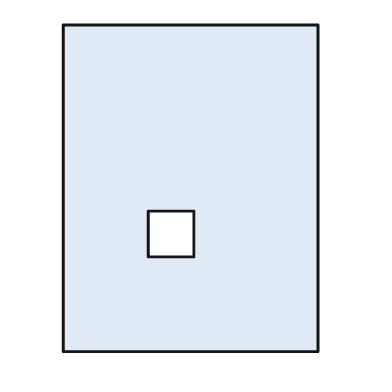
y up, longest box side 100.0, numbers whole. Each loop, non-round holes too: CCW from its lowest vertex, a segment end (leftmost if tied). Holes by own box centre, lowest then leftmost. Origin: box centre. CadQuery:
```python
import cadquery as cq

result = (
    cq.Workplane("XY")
    .moveTo(-39.0, -50.0)
    .lineTo(39.0, -50.0)
    .lineTo(39.0, 50.0)
    .lineTo(-39.0, 50.0)
    .close()
    .moveTo(-13.0, -21.0)
    .lineTo(1.0, -21.0)
    .lineTo(1.0, -7.0)
    .lineTo(-13.0, -7.0)
    .close()
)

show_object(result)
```